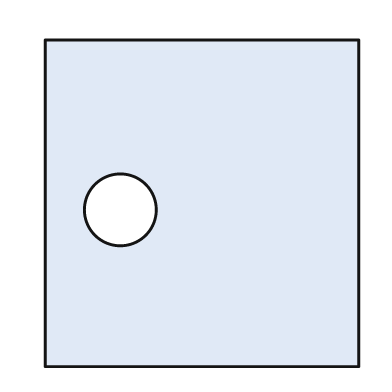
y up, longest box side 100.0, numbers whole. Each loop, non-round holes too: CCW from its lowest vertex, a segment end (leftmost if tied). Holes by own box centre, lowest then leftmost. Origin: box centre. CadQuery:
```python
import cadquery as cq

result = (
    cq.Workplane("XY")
    .moveTo(-48.0, -50.0)
    .lineTo(48.0, -50.0)
    .lineTo(48.0, 50.0)
    .lineTo(-48.0, 50.0)
    .close()
    .moveTo(-25.0, -2.0)
    .circle(11.0)
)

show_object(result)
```